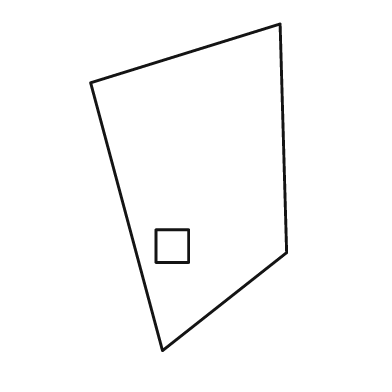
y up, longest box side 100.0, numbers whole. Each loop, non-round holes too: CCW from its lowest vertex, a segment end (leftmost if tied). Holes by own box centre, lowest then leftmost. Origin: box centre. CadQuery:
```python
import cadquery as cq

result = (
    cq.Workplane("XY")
    .moveTo(-8.0, -50.0)
    .lineTo(30.0, -20.0)
    .lineTo(28.0, 50.0)
    .lineTo(-30.0, 32.0)
    .close()
    .moveTo(-10.0, -23.0)
    .lineTo(0.0, -23.0)
    .lineTo(0.0, -13.0)
    .lineTo(-10.0, -13.0)
    .close()
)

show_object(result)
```